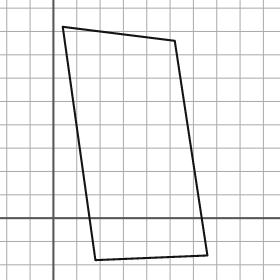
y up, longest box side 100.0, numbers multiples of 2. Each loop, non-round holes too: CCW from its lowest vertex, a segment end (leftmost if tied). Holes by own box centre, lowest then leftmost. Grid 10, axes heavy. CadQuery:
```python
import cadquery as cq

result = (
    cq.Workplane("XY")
    .moveTo(18.0, -18.0)
    .lineTo(66.0, -16.0)
    .lineTo(52.0, 76.0)
    .lineTo(4.0, 82.0)
    .close()
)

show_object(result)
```